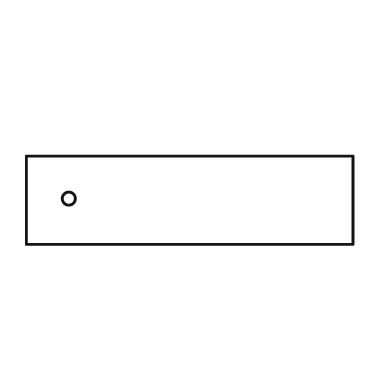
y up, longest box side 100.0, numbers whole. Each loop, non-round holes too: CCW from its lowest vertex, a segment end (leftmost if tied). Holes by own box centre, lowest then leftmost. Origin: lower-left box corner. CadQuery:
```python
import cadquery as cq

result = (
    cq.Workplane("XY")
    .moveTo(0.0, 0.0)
    .lineTo(100.0, 0.0)
    .lineTo(100.0, 27.0)
    .lineTo(0.0, 27.0)
    .close()
    .moveTo(13.0, 14.0)
    .circle(2.0)
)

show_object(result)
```